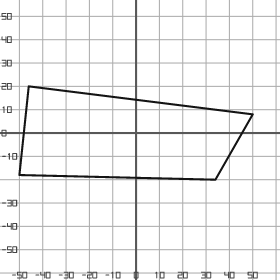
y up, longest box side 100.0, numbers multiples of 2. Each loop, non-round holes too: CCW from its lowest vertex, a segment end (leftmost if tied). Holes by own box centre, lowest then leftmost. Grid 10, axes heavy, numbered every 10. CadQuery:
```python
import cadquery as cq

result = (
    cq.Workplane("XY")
    .moveTo(34.0, -20.0)
    .lineTo(50.0, 8.0)
    .lineTo(-46.0, 20.0)
    .lineTo(-50.0, -18.0)
    .close()
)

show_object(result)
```